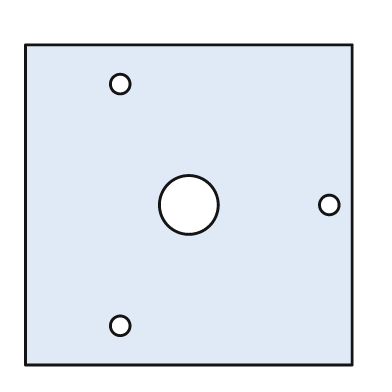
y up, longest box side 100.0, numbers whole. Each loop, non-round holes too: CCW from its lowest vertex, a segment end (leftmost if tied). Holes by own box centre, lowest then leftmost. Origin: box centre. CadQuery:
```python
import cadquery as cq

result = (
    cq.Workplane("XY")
    .moveTo(-50.0, -49.0)
    .lineTo(50.0, -49.0)
    .lineTo(50.0, 49.0)
    .lineTo(-50.0, 49.0)
    .close()
    .moveTo(-21.0, -37.0)
    .circle(3.0)
    .moveTo(0.0, 0.0)
    .circle(9.0)
    .moveTo(43.0, 0.0)
    .circle(3.0)
    .moveTo(-21.0, 37.0)
    .circle(3.0)
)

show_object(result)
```